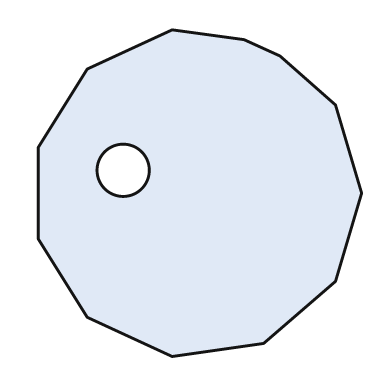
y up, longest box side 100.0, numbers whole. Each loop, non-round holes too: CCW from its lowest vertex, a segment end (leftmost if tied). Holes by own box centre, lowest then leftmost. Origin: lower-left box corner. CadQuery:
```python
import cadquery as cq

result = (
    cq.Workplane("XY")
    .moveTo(41.0, 0.0)
    .lineTo(69.0, 4.0)
    .lineTo(91.0, 23.0)
    .lineTo(99.0, 50.0)
    .lineTo(91.0, 77.0)
    .lineTo(74.0, 92.0)
    .lineTo(63.0, 97.0)
    .lineTo(41.0, 100.0)
    .lineTo(15.0, 88.0)
    .lineTo(0.0, 64.0)
    .lineTo(0.0, 36.0)
    .lineTo(15.0, 12.0)
    .close()
    .moveTo(26.0, 57.0)
    .circle(8.0)
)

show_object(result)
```